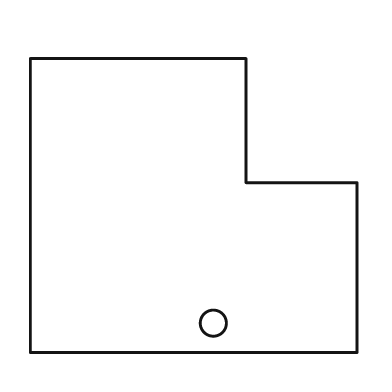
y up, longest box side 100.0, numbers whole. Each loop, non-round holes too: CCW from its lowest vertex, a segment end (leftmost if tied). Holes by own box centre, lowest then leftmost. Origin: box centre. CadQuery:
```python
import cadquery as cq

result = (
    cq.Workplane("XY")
    .moveTo(-50.0, -45.0)
    .lineTo(50.0, -45.0)
    .lineTo(50.0, 7.0)
    .lineTo(16.0, 7.0)
    .lineTo(16.0, 45.0)
    .lineTo(-50.0, 45.0)
    .close()
    .moveTo(6.0, -36.0)
    .circle(4.0)
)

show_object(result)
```